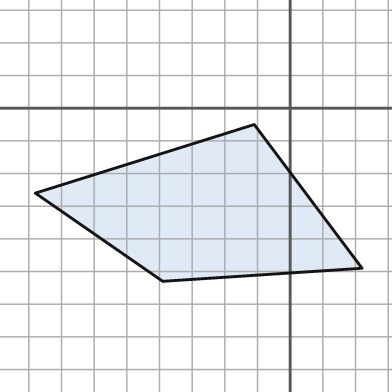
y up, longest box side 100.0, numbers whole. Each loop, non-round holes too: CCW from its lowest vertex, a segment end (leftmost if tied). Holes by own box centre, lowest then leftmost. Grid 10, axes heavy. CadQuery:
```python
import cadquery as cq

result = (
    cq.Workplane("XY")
    .moveTo(-39.0, -53.0)
    .lineTo(22.0, -49.0)
    .lineTo(-11.0, -5.0)
    .lineTo(-78.0, -26.0)
    .close()
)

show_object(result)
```